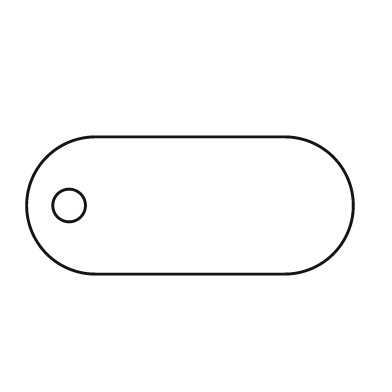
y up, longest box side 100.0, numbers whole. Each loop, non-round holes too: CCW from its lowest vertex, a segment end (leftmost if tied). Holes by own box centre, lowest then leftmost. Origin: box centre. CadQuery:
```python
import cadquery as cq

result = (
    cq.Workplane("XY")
    .moveTo(-29.0, -21.0)
    .lineTo(29.0, -21.0)
    .threePointArc((50.0, 0.0), (29.0, 21.0))
    .lineTo(-29.0, 21.0)
    .threePointArc((-50.0, 0.0), (-29.0, -21.0))
    .close()
    .moveTo(-37.0, 0.0)
    .circle(5.0)
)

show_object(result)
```